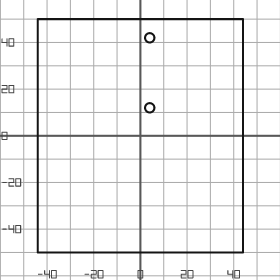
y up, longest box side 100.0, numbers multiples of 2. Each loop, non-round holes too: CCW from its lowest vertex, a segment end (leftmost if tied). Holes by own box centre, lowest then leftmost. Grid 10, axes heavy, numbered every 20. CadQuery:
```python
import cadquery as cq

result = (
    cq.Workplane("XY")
    .moveTo(-44.0, -50.0)
    .lineTo(44.0, -50.0)
    .lineTo(44.0, 50.0)
    .lineTo(-44.0, 50.0)
    .close()
    .moveTo(4.0, 12.0)
    .circle(2.0)
    .moveTo(4.0, 42.0)
    .circle(2.0)
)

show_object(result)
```